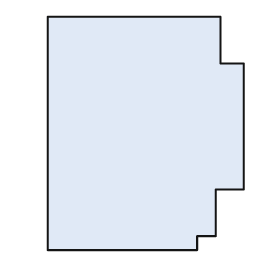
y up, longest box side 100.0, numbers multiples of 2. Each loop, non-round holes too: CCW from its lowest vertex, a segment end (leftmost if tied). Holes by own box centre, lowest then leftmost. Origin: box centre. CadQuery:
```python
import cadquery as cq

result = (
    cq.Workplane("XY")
    .moveTo(-42.0, -50.0)
    .lineTo(22.0, -50.0)
    .lineTo(22.0, -44.0)
    .lineTo(30.0, -44.0)
    .lineTo(30.0, -24.0)
    .lineTo(42.0, -24.0)
    .lineTo(42.0, 30.0)
    .lineTo(32.0, 30.0)
    .lineTo(32.0, 50.0)
    .lineTo(-42.0, 50.0)
    .close()
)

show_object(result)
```